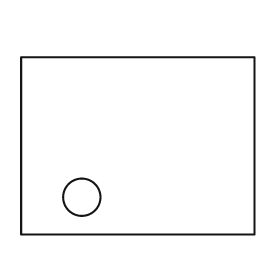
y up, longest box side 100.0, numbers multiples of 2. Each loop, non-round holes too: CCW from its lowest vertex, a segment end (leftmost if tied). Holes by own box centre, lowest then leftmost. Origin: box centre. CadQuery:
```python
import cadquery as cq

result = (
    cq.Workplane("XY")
    .moveTo(-50.0, -38.0)
    .lineTo(50.0, -38.0)
    .lineTo(50.0, 38.0)
    .lineTo(-50.0, 38.0)
    .close()
    .moveTo(-24.0, -22.0)
    .circle(8.0)
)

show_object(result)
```